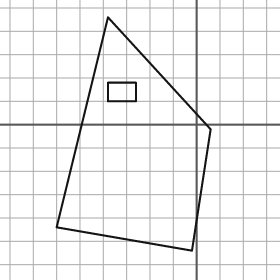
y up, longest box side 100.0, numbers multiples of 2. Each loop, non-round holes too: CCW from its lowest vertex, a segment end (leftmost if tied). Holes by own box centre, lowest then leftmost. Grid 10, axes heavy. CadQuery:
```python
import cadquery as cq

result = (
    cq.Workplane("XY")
    .moveTo(-2.0, -54.0)
    .lineTo(6.0, -2.0)
    .lineTo(-38.0, 46.0)
    .lineTo(-60.0, -44.0)
    .close()
    .moveTo(-38.0, 10.0)
    .lineTo(-26.0, 10.0)
    .lineTo(-26.0, 18.0)
    .lineTo(-38.0, 18.0)
    .close()
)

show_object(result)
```